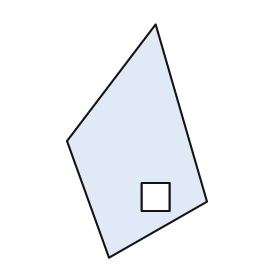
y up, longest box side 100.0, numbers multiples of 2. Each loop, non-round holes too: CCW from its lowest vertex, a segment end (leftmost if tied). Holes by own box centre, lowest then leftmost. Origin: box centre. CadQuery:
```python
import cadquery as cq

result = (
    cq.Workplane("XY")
    .moveTo(-12.0, -50.0)
    .lineTo(30.0, -26.0)
    .lineTo(8.0, 50.0)
    .lineTo(-30.0, 0.0)
    .close()
    .moveTo(2.0, -30.0)
    .lineTo(14.0, -30.0)
    .lineTo(14.0, -18.0)
    .lineTo(2.0, -18.0)
    .close()
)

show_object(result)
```